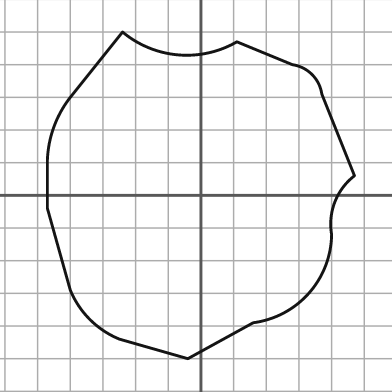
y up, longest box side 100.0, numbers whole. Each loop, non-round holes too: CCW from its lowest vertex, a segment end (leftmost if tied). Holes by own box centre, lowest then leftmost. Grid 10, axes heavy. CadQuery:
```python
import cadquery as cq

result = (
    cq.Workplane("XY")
    .moveTo(-4.0, -50.0)
    .lineTo(16.0, -39.0)
    .threePointArc((33.0, -30.0), (40.0, -12.0))
    .threePointArc((41.0, -2.0), (47.0, 6.0))
    .lineTo(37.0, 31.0)
    .threePointArc((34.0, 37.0), (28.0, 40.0))
    .lineTo(11.0, 47.0)
    .threePointArc((-7.0, 43.0), (-24.0, 50.0))
    .lineTo(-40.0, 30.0)
    .threePointArc((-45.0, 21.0), (-47.0, 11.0))
    .lineTo(-47.0, -4.0)
    .lineTo(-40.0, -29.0)
    .threePointArc((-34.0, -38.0), (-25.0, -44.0))
    .close()
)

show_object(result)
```